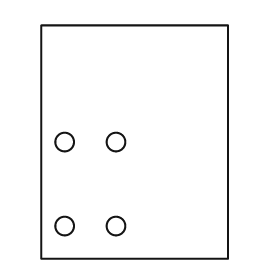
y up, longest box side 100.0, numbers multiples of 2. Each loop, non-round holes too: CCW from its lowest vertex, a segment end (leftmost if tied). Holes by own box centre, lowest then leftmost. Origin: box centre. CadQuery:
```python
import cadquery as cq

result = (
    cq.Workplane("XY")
    .moveTo(-40.0, -50.0)
    .lineTo(40.0, -50.0)
    .lineTo(40.0, 50.0)
    .lineTo(-40.0, 50.0)
    .close()
    .moveTo(-30.0, -36.0)
    .circle(4.0)
    .moveTo(-8.0, -36.0)
    .circle(4.0)
    .moveTo(-30.0, 0.0)
    .circle(4.0)
    .moveTo(-8.0, 0.0)
    .circle(4.0)
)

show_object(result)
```